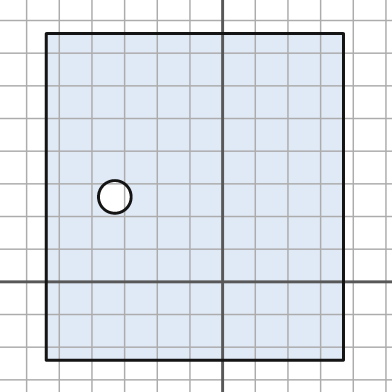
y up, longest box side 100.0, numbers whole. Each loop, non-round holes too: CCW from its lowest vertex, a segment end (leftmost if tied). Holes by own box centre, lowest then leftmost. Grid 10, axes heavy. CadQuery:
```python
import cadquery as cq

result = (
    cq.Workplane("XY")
    .moveTo(-54.0, -24.0)
    .lineTo(37.0, -24.0)
    .lineTo(37.0, 76.0)
    .lineTo(-54.0, 76.0)
    .close()
    .moveTo(-33.0, 26.0)
    .circle(5.0)
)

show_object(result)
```